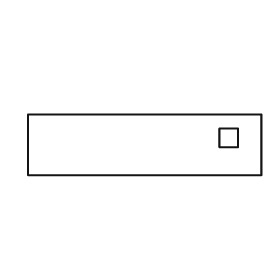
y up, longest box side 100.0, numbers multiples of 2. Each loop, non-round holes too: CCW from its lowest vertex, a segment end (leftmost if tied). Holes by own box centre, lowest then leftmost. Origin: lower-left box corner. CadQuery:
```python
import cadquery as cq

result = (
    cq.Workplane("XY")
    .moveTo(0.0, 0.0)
    .lineTo(100.0, 0.0)
    .lineTo(100.0, 26.0)
    .lineTo(0.0, 26.0)
    .close()
    .moveTo(82.0, 12.0)
    .lineTo(90.0, 12.0)
    .lineTo(90.0, 20.0)
    .lineTo(82.0, 20.0)
    .close()
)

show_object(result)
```